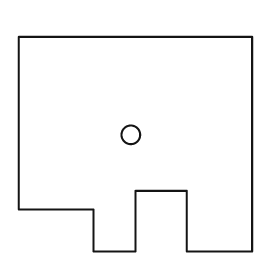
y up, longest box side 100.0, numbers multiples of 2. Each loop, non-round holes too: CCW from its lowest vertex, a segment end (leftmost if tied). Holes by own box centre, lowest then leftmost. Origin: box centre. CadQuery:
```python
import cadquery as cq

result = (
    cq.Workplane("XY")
    .moveTo(-18.0, -46.0)
    .lineTo(0.0, -46.0)
    .lineTo(0.0, -20.0)
    .lineTo(22.0, -20.0)
    .lineTo(22.0, -46.0)
    .lineTo(50.0, -46.0)
    .lineTo(50.0, 46.0)
    .lineTo(-50.0, 46.0)
    .lineTo(-50.0, -28.0)
    .lineTo(-18.0, -28.0)
    .close()
    .moveTo(-2.0, 4.0)
    .circle(4.0)
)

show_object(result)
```